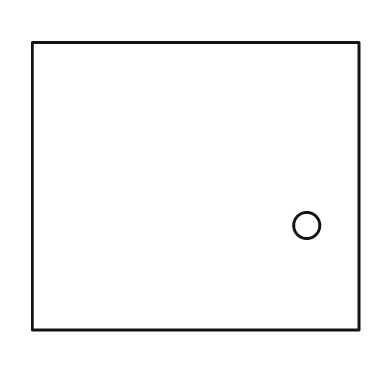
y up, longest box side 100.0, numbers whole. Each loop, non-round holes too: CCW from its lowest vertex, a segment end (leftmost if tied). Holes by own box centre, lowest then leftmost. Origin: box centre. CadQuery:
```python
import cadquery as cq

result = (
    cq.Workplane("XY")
    .moveTo(-50.0, -44.0)
    .lineTo(50.0, -44.0)
    .lineTo(50.0, 44.0)
    .lineTo(-50.0, 44.0)
    .close()
    .moveTo(34.0, -12.0)
    .circle(4.0)
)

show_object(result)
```